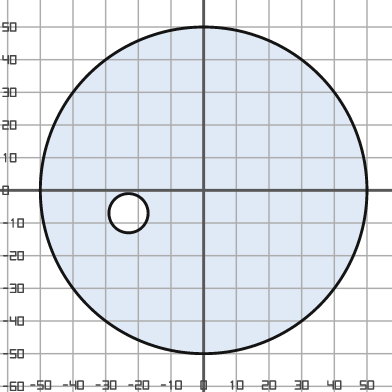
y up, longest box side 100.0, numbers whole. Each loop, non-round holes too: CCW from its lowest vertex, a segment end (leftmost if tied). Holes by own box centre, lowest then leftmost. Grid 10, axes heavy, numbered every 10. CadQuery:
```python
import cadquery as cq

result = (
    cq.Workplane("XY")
    .moveTo(0.0, 0.0)
    .circle(50.0)
    .moveTo(-23.0, -7.0)
    .circle(6.0)
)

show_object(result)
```